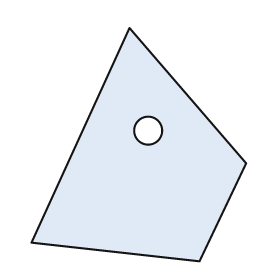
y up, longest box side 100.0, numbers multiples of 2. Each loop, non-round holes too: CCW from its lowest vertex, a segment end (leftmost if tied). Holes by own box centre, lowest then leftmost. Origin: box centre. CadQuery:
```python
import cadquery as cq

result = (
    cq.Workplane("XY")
    .moveTo(26.0, -50.0)
    .lineTo(46.0, -8.0)
    .lineTo(-4.0, 50.0)
    .lineTo(-46.0, -42.0)
    .close()
    .moveTo(4.0, 6.0)
    .circle(6.0)
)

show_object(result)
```